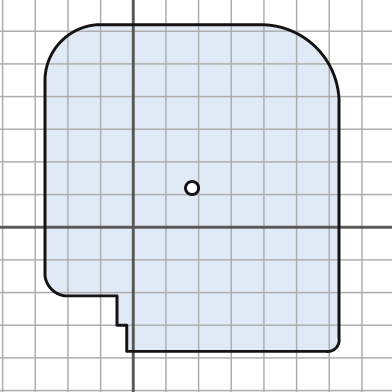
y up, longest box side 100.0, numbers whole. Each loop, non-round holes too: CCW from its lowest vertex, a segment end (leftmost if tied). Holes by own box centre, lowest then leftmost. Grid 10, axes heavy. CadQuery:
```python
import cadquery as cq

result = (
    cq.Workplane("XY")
    .moveTo(-2.0, -38.0)
    .lineTo(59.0, -38.0)
    .threePointArc((62.0, -37.0), (63.0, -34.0))
    .lineTo(63.0, 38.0)
    .threePointArc((56.0, 55.0), (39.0, 62.0))
    .lineTo(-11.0, 62.0)
    .threePointArc((-22.0, 57.0), (-27.0, 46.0))
    .lineTo(-27.0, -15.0)
    .threePointArc((-25.0, -19.0), (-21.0, -21.0))
    .lineTo(-5.0, -21.0)
    .lineTo(-5.0, -30.0)
    .lineTo(-2.0, -30.0)
    .close()
    .moveTo(18.0, 12.0)
    .circle(2.0)
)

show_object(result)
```